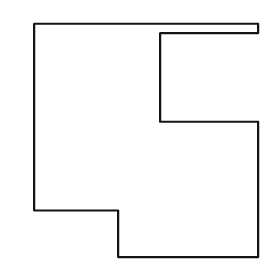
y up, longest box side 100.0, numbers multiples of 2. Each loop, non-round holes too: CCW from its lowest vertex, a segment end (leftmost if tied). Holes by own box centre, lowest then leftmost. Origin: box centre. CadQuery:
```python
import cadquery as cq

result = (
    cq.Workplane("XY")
    .moveTo(-12.0, -50.0)
    .lineTo(48.0, -50.0)
    .lineTo(48.0, 8.0)
    .lineTo(6.0, 8.0)
    .lineTo(6.0, 46.0)
    .lineTo(48.0, 46.0)
    .lineTo(48.0, 50.0)
    .lineTo(-48.0, 50.0)
    .lineTo(-48.0, -30.0)
    .lineTo(-12.0, -30.0)
    .close()
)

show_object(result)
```